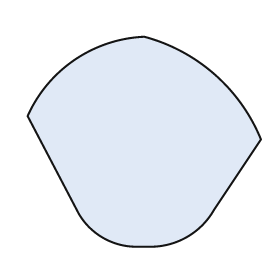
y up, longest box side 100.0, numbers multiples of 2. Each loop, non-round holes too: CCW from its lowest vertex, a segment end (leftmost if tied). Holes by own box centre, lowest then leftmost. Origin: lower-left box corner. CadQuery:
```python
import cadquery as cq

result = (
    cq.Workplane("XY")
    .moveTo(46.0, 0.0)
    .lineTo(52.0, 0.0)
    .threePointArc((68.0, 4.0), (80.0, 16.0))
    .lineTo(100.0, 46.0)
    .threePointArc((80.0, 74.0), (50.0, 90.0))
    .threePointArc((20.0, 80.0), (0.0, 56.0))
    .lineTo(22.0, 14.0)
    .threePointArc((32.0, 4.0), (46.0, 0.0))
    .close()
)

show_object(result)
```